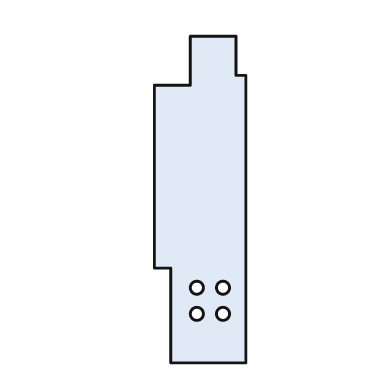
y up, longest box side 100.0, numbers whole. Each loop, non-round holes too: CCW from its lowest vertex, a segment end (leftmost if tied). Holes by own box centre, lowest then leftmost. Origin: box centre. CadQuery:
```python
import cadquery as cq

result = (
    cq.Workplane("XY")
    .moveTo(-9.0, -50.0)
    .lineTo(14.0, -50.0)
    .lineTo(14.0, 38.0)
    .lineTo(11.0, 38.0)
    .lineTo(11.0, 50.0)
    .lineTo(-3.0, 50.0)
    .lineTo(-3.0, 35.0)
    .lineTo(-14.0, 35.0)
    .lineTo(-14.0, -21.0)
    .lineTo(-9.0, -21.0)
    .close()
    .moveTo(-1.0, -35.0)
    .circle(2.0)
    .moveTo(7.0, -35.0)
    .circle(2.0)
    .moveTo(-1.0, -27.0)
    .circle(2.0)
    .moveTo(7.0, -27.0)
    .circle(2.0)
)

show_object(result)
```